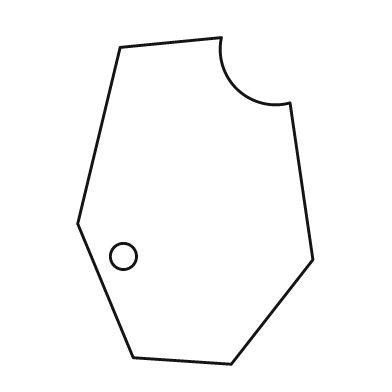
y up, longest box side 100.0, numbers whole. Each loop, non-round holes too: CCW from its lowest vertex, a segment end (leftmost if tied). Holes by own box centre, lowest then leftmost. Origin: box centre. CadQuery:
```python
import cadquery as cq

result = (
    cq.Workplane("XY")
    .moveTo(11.0, -50.0)
    .lineTo(36.0, -18.0)
    .lineTo(29.0, 30.0)
    .threePointArc((13.0, 34.0), (8.0, 50.0))
    .lineTo(-23.0, 47.0)
    .lineTo(-36.0, -7.0)
    .lineTo(-19.0, -48.0)
    .close()
    .moveTo(-22.0, -17.0)
    .circle(4.0)
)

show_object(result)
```